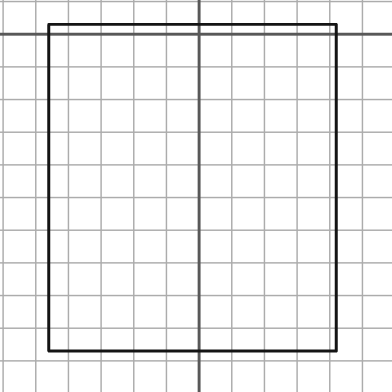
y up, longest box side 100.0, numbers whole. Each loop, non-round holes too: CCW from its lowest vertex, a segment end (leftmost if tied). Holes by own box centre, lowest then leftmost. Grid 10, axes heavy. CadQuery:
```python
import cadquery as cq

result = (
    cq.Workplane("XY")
    .moveTo(-46.0, -97.0)
    .lineTo(42.0, -97.0)
    .lineTo(42.0, 3.0)
    .lineTo(-46.0, 3.0)
    .close()
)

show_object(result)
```